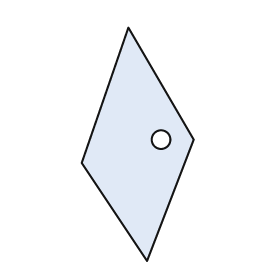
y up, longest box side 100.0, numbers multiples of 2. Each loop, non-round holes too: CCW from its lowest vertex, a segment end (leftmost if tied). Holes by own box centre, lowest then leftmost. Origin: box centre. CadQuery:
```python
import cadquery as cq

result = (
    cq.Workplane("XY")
    .moveTo(4.0, -50.0)
    .lineTo(24.0, 2.0)
    .lineTo(-4.0, 50.0)
    .lineTo(-24.0, -8.0)
    .close()
    .moveTo(10.0, 2.0)
    .circle(4.0)
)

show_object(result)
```